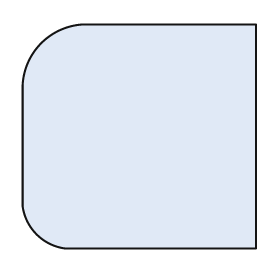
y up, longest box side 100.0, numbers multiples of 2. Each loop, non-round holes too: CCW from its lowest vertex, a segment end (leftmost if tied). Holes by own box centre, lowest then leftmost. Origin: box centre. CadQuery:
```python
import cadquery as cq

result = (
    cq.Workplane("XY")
    .moveTo(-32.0, -48.0)
    .lineTo(50.0, -48.0)
    .lineTo(50.0, 48.0)
    .lineTo(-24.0, 48.0)
    .threePointArc((-42.0, 40.0), (-50.0, 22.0))
    .lineTo(-50.0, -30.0)
    .threePointArc((-44.0, -42.0), (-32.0, -48.0))
    .close()
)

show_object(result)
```